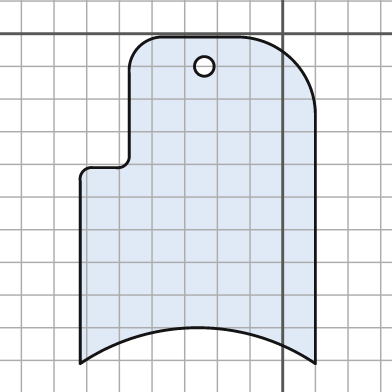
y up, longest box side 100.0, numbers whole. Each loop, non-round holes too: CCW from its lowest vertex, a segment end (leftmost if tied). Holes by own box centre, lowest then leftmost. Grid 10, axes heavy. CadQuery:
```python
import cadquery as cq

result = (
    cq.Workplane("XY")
    .moveTo(-62.0, -101.0)
    .threePointArc((-26.0, -90.0), (10.0, -101.0))
    .lineTo(10.0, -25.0)
    .threePointArc((3.0, -8.0), (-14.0, -1.0))
    .lineTo(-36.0, -1.0)
    .threePointArc((-44.0, -4.0), (-47.0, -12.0))
    .lineTo(-47.0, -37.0)
    .threePointArc((-48.0, -40.0), (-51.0, -41.0))
    .lineTo(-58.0, -41.0)
    .threePointArc((-61.0, -42.0), (-62.0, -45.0))
    .close()
    .moveTo(-24.0, -10.0)
    .circle(3.0)
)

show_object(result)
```